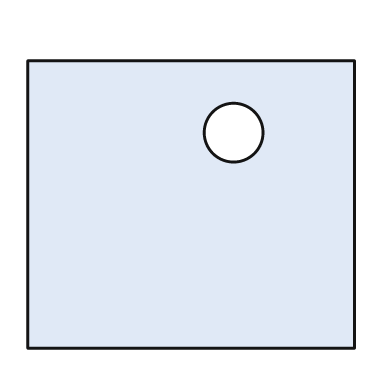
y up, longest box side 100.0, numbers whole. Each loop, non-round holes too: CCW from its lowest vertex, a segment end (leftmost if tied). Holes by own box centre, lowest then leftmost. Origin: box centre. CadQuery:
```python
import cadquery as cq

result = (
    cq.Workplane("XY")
    .moveTo(-50.0, -44.0)
    .lineTo(50.0, -44.0)
    .lineTo(50.0, 44.0)
    .lineTo(-50.0, 44.0)
    .close()
    .moveTo(13.0, 22.0)
    .circle(9.0)
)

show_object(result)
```